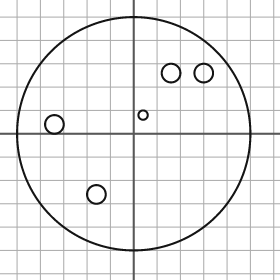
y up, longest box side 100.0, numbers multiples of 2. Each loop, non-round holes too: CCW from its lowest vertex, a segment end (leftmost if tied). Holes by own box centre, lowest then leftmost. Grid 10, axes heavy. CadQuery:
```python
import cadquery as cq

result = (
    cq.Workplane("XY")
    .moveTo(0.0, 0.0)
    .circle(50.0)
    .moveTo(-16.0, -26.0)
    .circle(4.0)
    .moveTo(-34.0, 4.0)
    .circle(4.0)
    .moveTo(4.0, 8.0)
    .circle(2.0)
    .moveTo(16.0, 26.0)
    .circle(4.0)
    .moveTo(30.0, 26.0)
    .circle(4.0)
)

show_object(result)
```